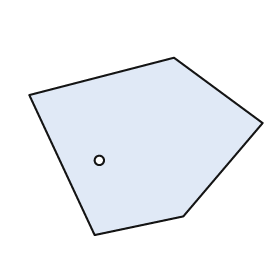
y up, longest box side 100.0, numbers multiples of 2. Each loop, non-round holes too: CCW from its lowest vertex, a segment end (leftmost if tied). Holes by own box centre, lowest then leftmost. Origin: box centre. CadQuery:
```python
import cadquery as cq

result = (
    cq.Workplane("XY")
    .moveTo(-22.0, -38.0)
    .lineTo(16.0, -30.0)
    .lineTo(50.0, 10.0)
    .lineTo(12.0, 38.0)
    .lineTo(-50.0, 22.0)
    .close()
    .moveTo(-20.0, -6.0)
    .circle(2.0)
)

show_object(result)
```